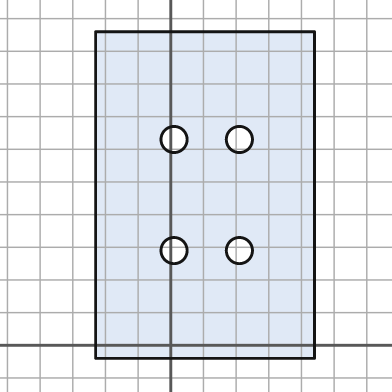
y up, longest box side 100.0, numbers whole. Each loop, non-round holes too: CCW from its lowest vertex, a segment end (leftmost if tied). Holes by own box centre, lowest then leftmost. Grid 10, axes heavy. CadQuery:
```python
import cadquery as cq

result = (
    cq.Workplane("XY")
    .moveTo(-23.0, -4.0)
    .lineTo(44.0, -4.0)
    .lineTo(44.0, 96.0)
    .lineTo(-23.0, 96.0)
    .close()
    .moveTo(1.0, 29.0)
    .circle(4.0)
    .moveTo(21.0, 29.0)
    .circle(4.0)
    .moveTo(1.0, 63.0)
    .circle(4.0)
    .moveTo(21.0, 63.0)
    .circle(4.0)
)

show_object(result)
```